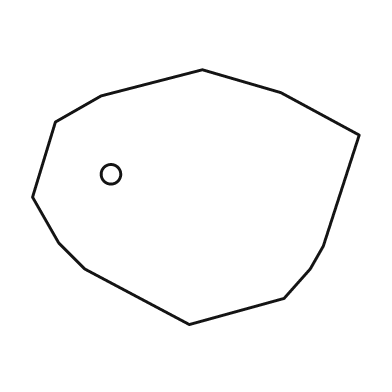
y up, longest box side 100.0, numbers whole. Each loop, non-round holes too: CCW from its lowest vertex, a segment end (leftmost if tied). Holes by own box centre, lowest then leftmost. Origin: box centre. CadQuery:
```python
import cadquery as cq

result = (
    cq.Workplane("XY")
    .moveTo(-2.0, -39.0)
    .lineTo(27.0, -31.0)
    .lineTo(35.0, -22.0)
    .lineTo(39.0, -15.0)
    .lineTo(50.0, 19.0)
    .lineTo(26.0, 32.0)
    .lineTo(2.0, 39.0)
    .lineTo(-29.0, 31.0)
    .lineTo(-43.0, 23.0)
    .lineTo(-50.0, 0.0)
    .lineTo(-42.0, -14.0)
    .lineTo(-34.0, -22.0)
    .close()
    .moveTo(-26.0, 7.0)
    .circle(3.0)
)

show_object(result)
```